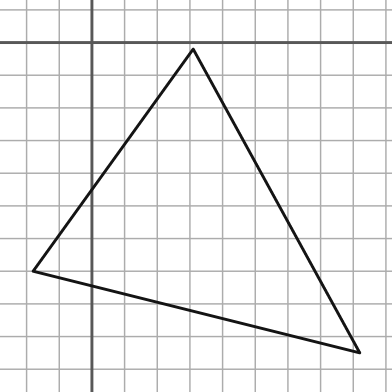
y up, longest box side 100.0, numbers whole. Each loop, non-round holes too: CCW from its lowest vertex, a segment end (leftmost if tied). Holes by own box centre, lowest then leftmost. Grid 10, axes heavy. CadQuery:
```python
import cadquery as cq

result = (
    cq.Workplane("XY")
    .moveTo(82.0, -95.0)
    .lineTo(31.0, -2.0)
    .lineTo(-18.0, -70.0)
    .close()
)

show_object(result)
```